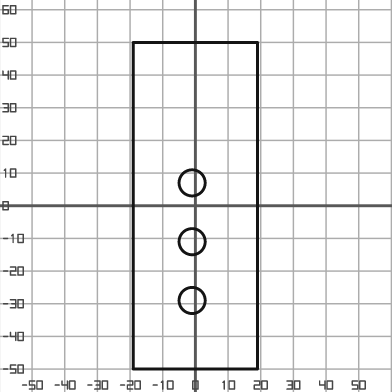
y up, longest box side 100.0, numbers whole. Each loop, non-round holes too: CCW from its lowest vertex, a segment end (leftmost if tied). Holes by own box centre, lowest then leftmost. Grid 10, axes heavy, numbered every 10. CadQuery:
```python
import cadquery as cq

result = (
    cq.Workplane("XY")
    .moveTo(-19.0, -50.0)
    .lineTo(19.0, -50.0)
    .lineTo(19.0, 50.0)
    .lineTo(-19.0, 50.0)
    .close()
    .moveTo(-1.0, -29.0)
    .circle(4.0)
    .moveTo(-1.0, -11.0)
    .circle(4.0)
    .moveTo(-1.0, 7.0)
    .circle(4.0)
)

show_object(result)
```